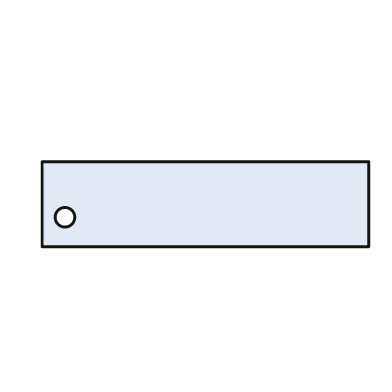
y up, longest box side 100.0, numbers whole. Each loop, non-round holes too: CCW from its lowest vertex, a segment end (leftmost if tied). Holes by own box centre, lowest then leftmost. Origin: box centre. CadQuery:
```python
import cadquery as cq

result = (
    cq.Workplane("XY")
    .moveTo(-50.0, -13.0)
    .lineTo(50.0, -13.0)
    .lineTo(50.0, 13.0)
    .lineTo(-50.0, 13.0)
    .close()
    .moveTo(-43.0, -4.0)
    .circle(3.0)
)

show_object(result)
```